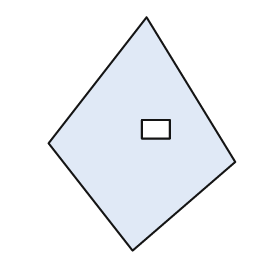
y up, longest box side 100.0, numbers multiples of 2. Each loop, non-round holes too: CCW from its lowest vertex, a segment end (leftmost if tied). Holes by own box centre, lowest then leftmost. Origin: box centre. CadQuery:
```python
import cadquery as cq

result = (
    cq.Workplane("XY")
    .moveTo(-4.0, -50.0)
    .lineTo(40.0, -12.0)
    .lineTo(2.0, 50.0)
    .lineTo(-40.0, -4.0)
    .close()
    .moveTo(0.0, -2.0)
    .lineTo(12.0, -2.0)
    .lineTo(12.0, 6.0)
    .lineTo(0.0, 6.0)
    .close()
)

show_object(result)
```